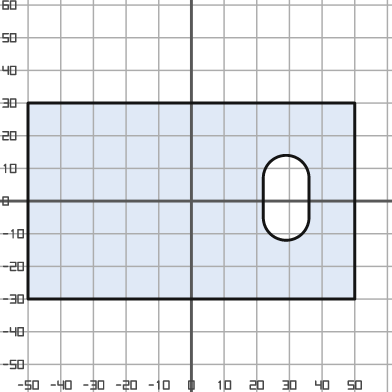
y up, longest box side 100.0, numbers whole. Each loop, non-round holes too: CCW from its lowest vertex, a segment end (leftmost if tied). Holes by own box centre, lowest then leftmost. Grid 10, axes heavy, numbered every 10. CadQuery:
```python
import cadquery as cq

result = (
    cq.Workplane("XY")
    .moveTo(-50.0, -30.0)
    .lineTo(50.0, -30.0)
    .lineTo(50.0, 30.0)
    .lineTo(-50.0, 30.0)
    .close()
    .moveTo(22.0, -5.0)
    .threePointArc((29.0, -12.0), (36.0, -5.0))
    .lineTo(36.0, 7.0)
    .threePointArc((29.0, 14.0), (22.0, 7.0))
    .close()
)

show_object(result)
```